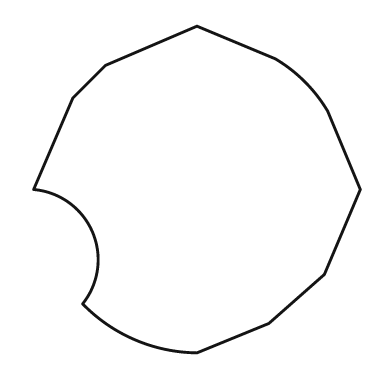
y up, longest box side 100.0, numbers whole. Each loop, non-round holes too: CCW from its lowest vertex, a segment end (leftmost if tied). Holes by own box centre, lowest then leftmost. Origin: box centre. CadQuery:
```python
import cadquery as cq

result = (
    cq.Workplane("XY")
    .moveTo(0.0, -50.0)
    .lineTo(22.0, -41.0)
    .lineTo(39.0, -26.0)
    .lineTo(50.0, 0.0)
    .lineTo(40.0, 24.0)
    .threePointArc((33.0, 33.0), (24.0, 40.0))
    .lineTo(0.0, 50.0)
    .lineTo(-28.0, 38.0)
    .lineTo(-38.0, 28.0)
    .lineTo(-50.0, 0.0)
    .threePointArc((-32.0, -13.0), (-35.0, -35.0))
    .threePointArc((-19.0, -46.0), (0.0, -50.0))
    .close()
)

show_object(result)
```